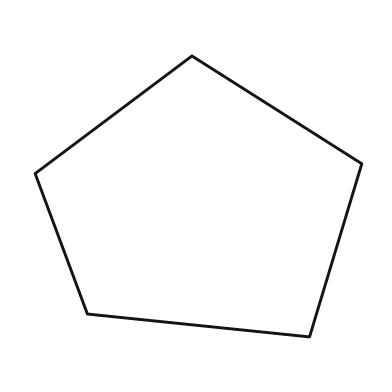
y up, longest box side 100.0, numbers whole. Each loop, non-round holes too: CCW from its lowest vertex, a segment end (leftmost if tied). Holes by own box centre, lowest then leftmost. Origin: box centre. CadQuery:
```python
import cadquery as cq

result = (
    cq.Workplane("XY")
    .moveTo(34.0, -43.0)
    .lineTo(50.0, 10.0)
    .lineTo(-2.0, 43.0)
    .lineTo(-50.0, 7.0)
    .lineTo(-34.0, -36.0)
    .close()
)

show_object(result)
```